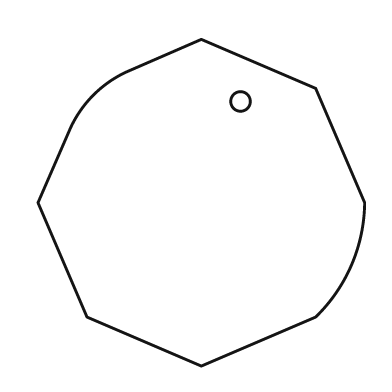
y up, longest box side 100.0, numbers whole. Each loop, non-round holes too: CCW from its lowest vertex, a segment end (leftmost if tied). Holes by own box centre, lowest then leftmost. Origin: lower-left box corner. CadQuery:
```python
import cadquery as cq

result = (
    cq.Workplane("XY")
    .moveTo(50.0, 0.0)
    .lineTo(85.0, 15.0)
    .threePointArc((96.0, 31.0), (100.0, 50.0))
    .lineTo(85.0, 85.0)
    .lineTo(50.0, 100.0)
    .lineTo(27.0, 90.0)
    .threePointArc((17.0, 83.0), (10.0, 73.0))
    .lineTo(0.0, 50.0)
    .lineTo(15.0, 15.0)
    .close()
    .moveTo(62.0, 81.0)
    .circle(3.0)
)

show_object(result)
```